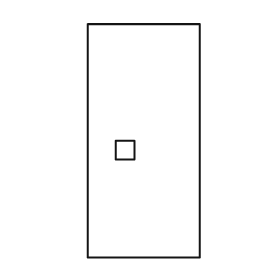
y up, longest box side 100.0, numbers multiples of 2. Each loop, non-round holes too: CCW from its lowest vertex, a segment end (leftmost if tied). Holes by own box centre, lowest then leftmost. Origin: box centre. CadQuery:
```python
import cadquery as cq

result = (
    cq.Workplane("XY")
    .moveTo(-24.0, -50.0)
    .lineTo(24.0, -50.0)
    .lineTo(24.0, 50.0)
    .lineTo(-24.0, 50.0)
    .close()
    .moveTo(-12.0, -8.0)
    .lineTo(-4.0, -8.0)
    .lineTo(-4.0, 0.0)
    .lineTo(-12.0, 0.0)
    .close()
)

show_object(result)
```